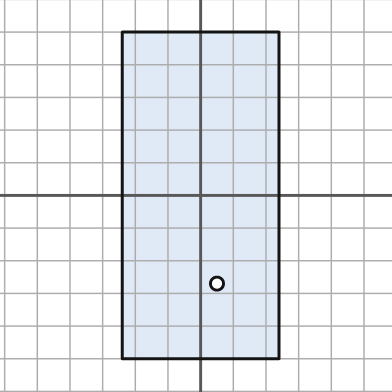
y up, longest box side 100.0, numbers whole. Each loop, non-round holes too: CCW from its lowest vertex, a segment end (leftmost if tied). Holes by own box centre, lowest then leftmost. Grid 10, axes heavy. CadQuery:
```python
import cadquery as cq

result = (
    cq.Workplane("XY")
    .moveTo(-24.0, -50.0)
    .lineTo(24.0, -50.0)
    .lineTo(24.0, 50.0)
    .lineTo(-24.0, 50.0)
    .close()
    .moveTo(5.0, -27.0)
    .circle(2.0)
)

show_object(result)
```